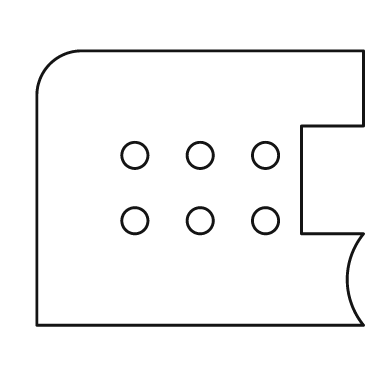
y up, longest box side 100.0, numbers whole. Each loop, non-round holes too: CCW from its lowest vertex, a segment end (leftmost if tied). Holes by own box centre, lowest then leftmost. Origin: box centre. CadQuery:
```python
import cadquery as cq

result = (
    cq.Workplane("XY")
    .moveTo(-50.0, -42.0)
    .lineTo(50.0, -42.0)
    .threePointArc((45.0, -28.0), (50.0, -14.0))
    .lineTo(31.0, -14.0)
    .lineTo(31.0, 19.0)
    .lineTo(50.0, 19.0)
    .lineTo(50.0, 42.0)
    .lineTo(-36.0, 42.0)
    .threePointArc((-46.0, 38.0), (-50.0, 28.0))
    .close()
    .moveTo(-20.0, -10.0)
    .circle(4.0)
    .moveTo(0.0, -10.0)
    .circle(4.0)
    .moveTo(20.0, -10.0)
    .circle(4.0)
    .moveTo(-20.0, 10.0)
    .circle(4.0)
    .moveTo(0.0, 10.0)
    .circle(4.0)
    .moveTo(20.0, 10.0)
    .circle(4.0)
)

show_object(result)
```